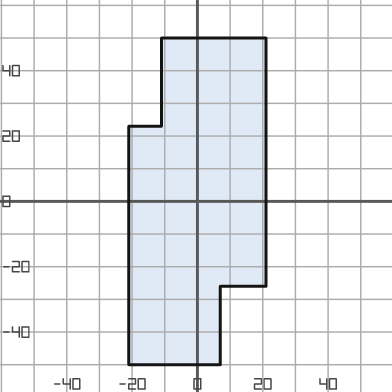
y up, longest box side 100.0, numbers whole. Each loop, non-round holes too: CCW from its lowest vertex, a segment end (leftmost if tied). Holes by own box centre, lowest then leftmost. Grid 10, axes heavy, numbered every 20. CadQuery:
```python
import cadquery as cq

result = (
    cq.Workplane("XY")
    .moveTo(-21.0, -50.0)
    .lineTo(7.0, -50.0)
    .lineTo(7.0, -26.0)
    .lineTo(21.0, -26.0)
    .lineTo(21.0, 50.0)
    .lineTo(-11.0, 50.0)
    .lineTo(-11.0, 23.0)
    .lineTo(-21.0, 23.0)
    .close()
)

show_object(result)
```